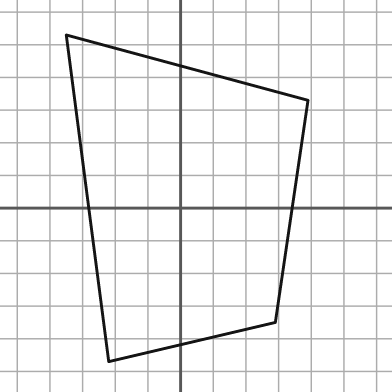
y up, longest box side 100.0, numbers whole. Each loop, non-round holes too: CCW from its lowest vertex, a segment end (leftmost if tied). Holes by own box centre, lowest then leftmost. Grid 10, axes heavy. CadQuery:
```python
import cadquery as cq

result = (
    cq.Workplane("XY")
    .moveTo(-22.0, -47.0)
    .lineTo(29.0, -35.0)
    .lineTo(39.0, 33.0)
    .lineTo(-35.0, 53.0)
    .close()
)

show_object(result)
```